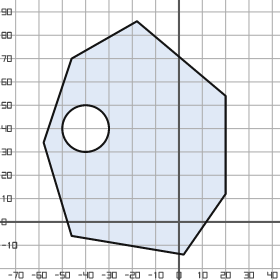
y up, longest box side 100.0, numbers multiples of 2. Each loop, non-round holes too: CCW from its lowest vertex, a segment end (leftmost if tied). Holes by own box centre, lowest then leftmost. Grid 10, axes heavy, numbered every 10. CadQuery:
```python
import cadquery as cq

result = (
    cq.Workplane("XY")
    .moveTo(2.0, -14.0)
    .lineTo(20.0, 12.0)
    .lineTo(20.0, 54.0)
    .lineTo(-18.0, 86.0)
    .lineTo(-46.0, 70.0)
    .lineTo(-58.0, 34.0)
    .lineTo(-46.0, -6.0)
    .close()
    .moveTo(-40.0, 40.0)
    .circle(10.0)
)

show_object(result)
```